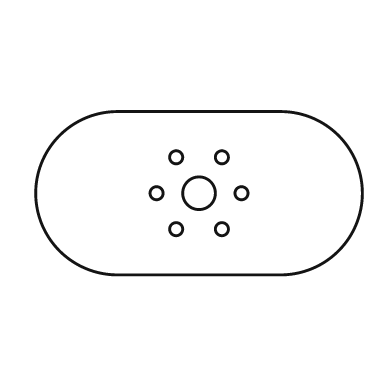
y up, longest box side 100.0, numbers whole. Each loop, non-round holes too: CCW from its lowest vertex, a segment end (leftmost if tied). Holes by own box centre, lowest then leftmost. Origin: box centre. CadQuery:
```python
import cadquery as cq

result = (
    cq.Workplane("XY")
    .moveTo(-25.0, -25.0)
    .lineTo(25.0, -25.0)
    .threePointArc((50.0, 0.0), (25.0, 25.0))
    .lineTo(-25.0, 25.0)
    .threePointArc((-50.0, 0.0), (-25.0, -25.0))
    .close()
    .moveTo(-7.0, -11.0)
    .circle(2.0)
    .moveTo(7.0, -11.0)
    .circle(2.0)
    .moveTo(-13.0, 0.0)
    .circle(2.0)
    .moveTo(0.0, 0.0)
    .circle(5.0)
    .moveTo(13.0, 0.0)
    .circle(2.0)
    .moveTo(-7.0, 11.0)
    .circle(2.0)
    .moveTo(7.0, 11.0)
    .circle(2.0)
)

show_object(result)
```